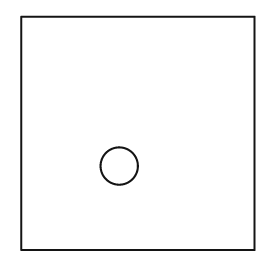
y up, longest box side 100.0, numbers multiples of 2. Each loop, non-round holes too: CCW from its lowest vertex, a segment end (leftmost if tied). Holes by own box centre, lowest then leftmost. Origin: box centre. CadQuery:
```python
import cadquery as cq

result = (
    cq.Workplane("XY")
    .moveTo(-50.0, -50.0)
    .lineTo(50.0, -50.0)
    .lineTo(50.0, 50.0)
    .lineTo(-50.0, 50.0)
    .close()
    .moveTo(-8.0, -14.0)
    .circle(8.0)
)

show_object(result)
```